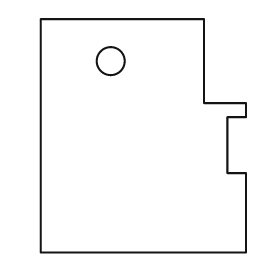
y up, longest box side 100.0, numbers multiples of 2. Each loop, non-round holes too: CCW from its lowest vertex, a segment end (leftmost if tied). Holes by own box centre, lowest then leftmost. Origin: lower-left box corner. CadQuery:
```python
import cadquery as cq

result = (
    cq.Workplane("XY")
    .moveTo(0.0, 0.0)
    .lineTo(88.0, 0.0)
    .lineTo(88.0, 34.0)
    .lineTo(80.0, 34.0)
    .lineTo(80.0, 58.0)
    .lineTo(88.0, 58.0)
    .lineTo(88.0, 64.0)
    .lineTo(70.0, 64.0)
    .lineTo(70.0, 100.0)
    .lineTo(0.0, 100.0)
    .close()
    .moveTo(30.0, 82.0)
    .circle(6.0)
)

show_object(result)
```